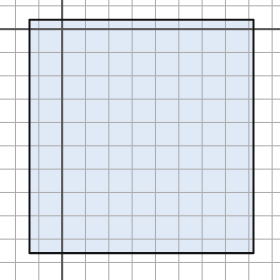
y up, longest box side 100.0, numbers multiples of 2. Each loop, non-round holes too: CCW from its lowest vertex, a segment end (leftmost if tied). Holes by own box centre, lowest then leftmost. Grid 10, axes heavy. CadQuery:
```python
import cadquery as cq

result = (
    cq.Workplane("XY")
    .moveTo(-14.0, -96.0)
    .lineTo(82.0, -96.0)
    .lineTo(82.0, 4.0)
    .lineTo(-14.0, 4.0)
    .close()
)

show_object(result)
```